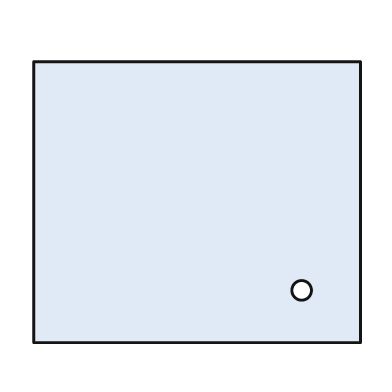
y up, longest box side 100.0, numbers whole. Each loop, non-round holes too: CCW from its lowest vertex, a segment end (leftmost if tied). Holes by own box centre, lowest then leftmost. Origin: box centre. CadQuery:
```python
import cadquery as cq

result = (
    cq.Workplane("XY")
    .moveTo(-50.0, -43.0)
    .lineTo(50.0, -43.0)
    .lineTo(50.0, 43.0)
    .lineTo(-50.0, 43.0)
    .close()
    .moveTo(32.0, -27.0)
    .circle(3.0)
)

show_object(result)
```